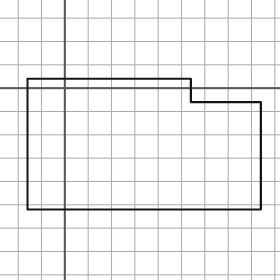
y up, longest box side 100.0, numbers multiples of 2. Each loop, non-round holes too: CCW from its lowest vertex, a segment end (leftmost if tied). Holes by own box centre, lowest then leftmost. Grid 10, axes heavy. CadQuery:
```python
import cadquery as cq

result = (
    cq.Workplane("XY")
    .moveTo(-16.0, -52.0)
    .lineTo(84.0, -52.0)
    .lineTo(84.0, -6.0)
    .lineTo(54.0, -6.0)
    .lineTo(54.0, 4.0)
    .lineTo(-16.0, 4.0)
    .close()
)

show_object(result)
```